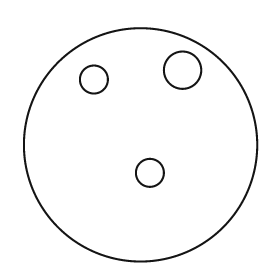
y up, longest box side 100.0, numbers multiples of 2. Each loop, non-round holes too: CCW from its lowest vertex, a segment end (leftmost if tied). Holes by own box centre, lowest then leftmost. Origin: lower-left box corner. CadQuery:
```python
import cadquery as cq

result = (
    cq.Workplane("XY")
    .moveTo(50.0, 50.0)
    .circle(50.0)
    .moveTo(54.0, 38.0)
    .circle(6.0)
    .moveTo(30.0, 78.0)
    .circle(6.0)
    .moveTo(68.0, 82.0)
    .circle(8.0)
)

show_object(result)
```